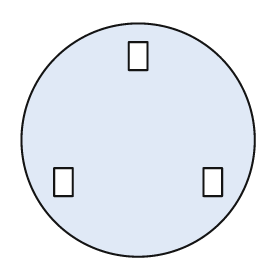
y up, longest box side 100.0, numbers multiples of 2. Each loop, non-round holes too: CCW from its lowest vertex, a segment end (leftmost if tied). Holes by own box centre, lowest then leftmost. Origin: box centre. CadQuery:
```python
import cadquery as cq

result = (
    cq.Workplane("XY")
    .moveTo(0.0, 0.0)
    .circle(50.0)
    .moveTo(-36.0, -24.0)
    .lineTo(-28.0, -24.0)
    .lineTo(-28.0, -12.0)
    .lineTo(-36.0, -12.0)
    .close()
    .moveTo(28.0, -24.0)
    .lineTo(36.0, -24.0)
    .lineTo(36.0, -12.0)
    .lineTo(28.0, -12.0)
    .close()
    .moveTo(-4.0, 30.0)
    .lineTo(4.0, 30.0)
    .lineTo(4.0, 42.0)
    .lineTo(-4.0, 42.0)
    .close()
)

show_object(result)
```